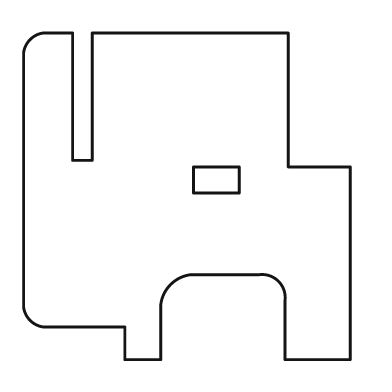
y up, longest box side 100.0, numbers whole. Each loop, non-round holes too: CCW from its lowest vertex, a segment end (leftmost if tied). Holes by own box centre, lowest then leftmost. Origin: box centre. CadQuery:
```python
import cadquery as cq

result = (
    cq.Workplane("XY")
    .moveTo(-19.0, -50.0)
    .lineTo(-8.0, -50.0)
    .lineTo(-8.0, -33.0)
    .threePointArc((-5.0, -27.0), (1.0, -24.0))
    .lineTo(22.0, -24.0)
    .threePointArc((28.0, -26.0), (30.0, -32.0))
    .lineTo(30.0, -50.0)
    .lineTo(50.0, -50.0)
    .lineTo(50.0, 9.0)
    .lineTo(31.0, 9.0)
    .lineTo(31.0, 50.0)
    .lineTo(-29.0, 50.0)
    .lineTo(-29.0, 11.0)
    .lineTo(-35.0, 11.0)
    .lineTo(-35.0, 50.0)
    .lineTo(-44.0, 50.0)
    .threePointArc((-48.0, 48.0), (-50.0, 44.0))
    .lineTo(-50.0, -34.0)
    .threePointArc((-48.0, -38.0), (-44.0, -40.0))
    .lineTo(-19.0, -40.0)
    .close()
    .moveTo(2.0, 1.0)
    .lineTo(16.0, 1.0)
    .lineTo(16.0, 9.0)
    .lineTo(2.0, 9.0)
    .close()
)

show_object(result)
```